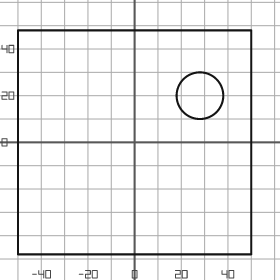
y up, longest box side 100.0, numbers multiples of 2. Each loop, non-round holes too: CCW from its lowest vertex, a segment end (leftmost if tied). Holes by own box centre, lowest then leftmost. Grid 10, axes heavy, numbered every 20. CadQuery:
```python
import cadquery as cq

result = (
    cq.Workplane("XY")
    .moveTo(-50.0, -48.0)
    .lineTo(50.0, -48.0)
    .lineTo(50.0, 48.0)
    .lineTo(-50.0, 48.0)
    .close()
    .moveTo(28.0, 20.0)
    .circle(10.0)
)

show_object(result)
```